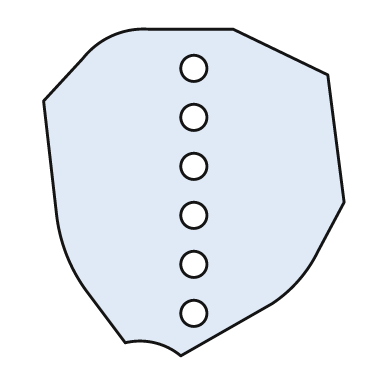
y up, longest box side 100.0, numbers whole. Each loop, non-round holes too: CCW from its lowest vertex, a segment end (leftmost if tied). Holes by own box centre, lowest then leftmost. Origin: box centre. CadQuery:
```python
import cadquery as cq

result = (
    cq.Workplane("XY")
    .moveTo(-4.0, -50.0)
    .lineTo(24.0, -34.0)
    .threePointArc((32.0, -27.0), (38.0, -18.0))
    .lineTo(46.0, -3.0)
    .lineTo(41.0, 36.0)
    .lineTo(12.0, 50.0)
    .lineTo(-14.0, 50.0)
    .threePointArc((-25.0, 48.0), (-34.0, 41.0))
    .lineTo(-46.0, 28.0)
    .lineTo(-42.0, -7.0)
    .threePointArc((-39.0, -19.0), (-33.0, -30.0))
    .lineTo(-21.0, -46.0)
    .threePointArc((-12.0, -46.0), (-4.0, -50.0))
    .close()
    .moveTo(0.0, -37.0)
    .circle(4.0)
    .moveTo(0.0, -22.0)
    .circle(4.0)
    .moveTo(0.0, -7.0)
    .circle(4.0)
    .moveTo(0.0, 8.0)
    .circle(4.0)
    .moveTo(0.0, 23.0)
    .circle(4.0)
    .moveTo(0.0, 38.0)
    .circle(4.0)
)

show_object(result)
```